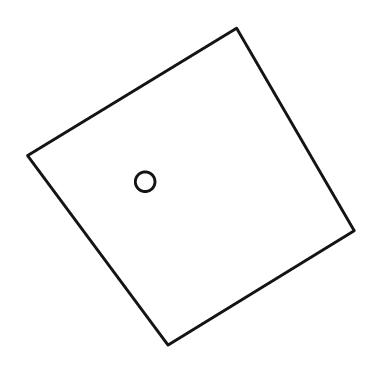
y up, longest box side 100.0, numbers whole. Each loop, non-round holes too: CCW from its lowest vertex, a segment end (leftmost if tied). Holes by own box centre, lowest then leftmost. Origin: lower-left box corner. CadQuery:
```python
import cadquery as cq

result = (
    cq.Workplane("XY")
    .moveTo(43.0, 0.0)
    .lineTo(100.0, 35.0)
    .lineTo(64.0, 97.0)
    .lineTo(0.0, 58.0)
    .close()
    .moveTo(36.0, 50.0)
    .circle(3.0)
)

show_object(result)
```